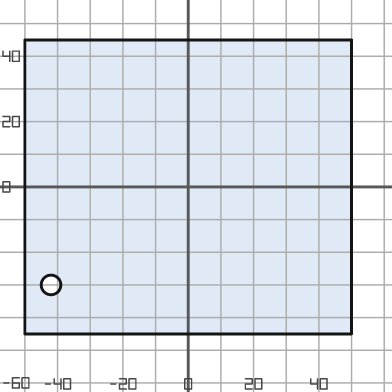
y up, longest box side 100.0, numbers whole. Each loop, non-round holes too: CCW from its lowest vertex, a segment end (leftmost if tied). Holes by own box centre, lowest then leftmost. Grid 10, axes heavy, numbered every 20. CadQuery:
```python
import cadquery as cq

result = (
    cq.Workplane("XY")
    .moveTo(-50.0, -45.0)
    .lineTo(50.0, -45.0)
    .lineTo(50.0, 45.0)
    .lineTo(-50.0, 45.0)
    .close()
    .moveTo(-42.0, -30.0)
    .circle(3.0)
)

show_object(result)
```